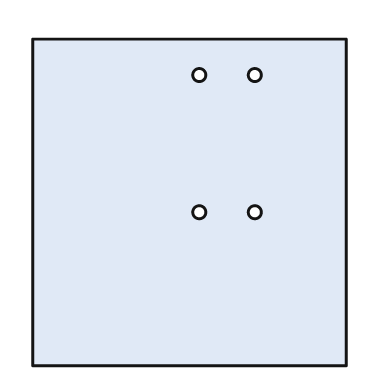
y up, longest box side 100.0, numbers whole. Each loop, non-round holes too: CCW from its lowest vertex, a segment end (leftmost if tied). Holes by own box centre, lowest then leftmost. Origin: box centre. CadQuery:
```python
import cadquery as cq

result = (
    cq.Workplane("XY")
    .moveTo(-48.0, -50.0)
    .lineTo(48.0, -50.0)
    .lineTo(48.0, 50.0)
    .lineTo(-48.0, 50.0)
    .close()
    .moveTo(3.0, -3.0)
    .circle(2.0)
    .moveTo(20.0, -3.0)
    .circle(2.0)
    .moveTo(3.0, 39.0)
    .circle(2.0)
    .moveTo(20.0, 39.0)
    .circle(2.0)
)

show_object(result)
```